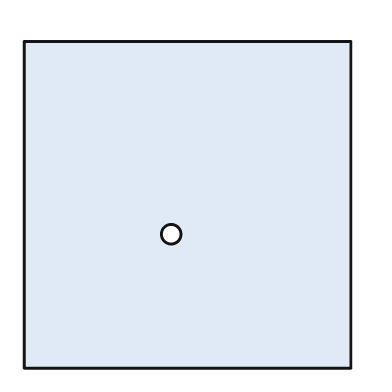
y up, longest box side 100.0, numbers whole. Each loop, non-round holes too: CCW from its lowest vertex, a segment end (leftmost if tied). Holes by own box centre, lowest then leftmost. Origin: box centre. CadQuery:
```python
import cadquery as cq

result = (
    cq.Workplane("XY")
    .moveTo(-50.0, -50.0)
    .lineTo(50.0, -50.0)
    .lineTo(50.0, 50.0)
    .lineTo(-50.0, 50.0)
    .close()
    .moveTo(-5.0, -9.0)
    .circle(3.0)
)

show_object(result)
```